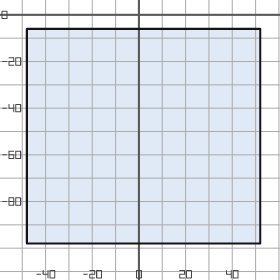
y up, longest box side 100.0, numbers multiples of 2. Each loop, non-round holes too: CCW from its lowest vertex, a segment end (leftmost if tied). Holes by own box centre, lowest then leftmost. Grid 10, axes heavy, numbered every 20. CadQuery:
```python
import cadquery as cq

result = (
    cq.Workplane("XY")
    .moveTo(-48.0, -98.0)
    .lineTo(52.0, -98.0)
    .lineTo(52.0, -6.0)
    .lineTo(-48.0, -6.0)
    .close()
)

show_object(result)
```